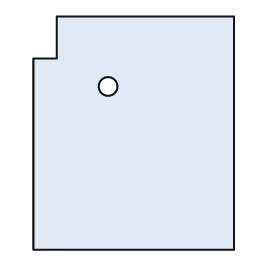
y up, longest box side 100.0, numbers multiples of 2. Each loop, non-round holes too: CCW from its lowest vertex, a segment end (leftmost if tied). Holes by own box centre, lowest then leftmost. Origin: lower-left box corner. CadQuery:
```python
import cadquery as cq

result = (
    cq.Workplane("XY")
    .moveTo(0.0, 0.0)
    .lineTo(86.0, 0.0)
    .lineTo(86.0, 100.0)
    .lineTo(10.0, 100.0)
    .lineTo(10.0, 82.0)
    .lineTo(0.0, 82.0)
    .close()
    .moveTo(32.0, 70.0)
    .circle(4.0)
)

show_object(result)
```